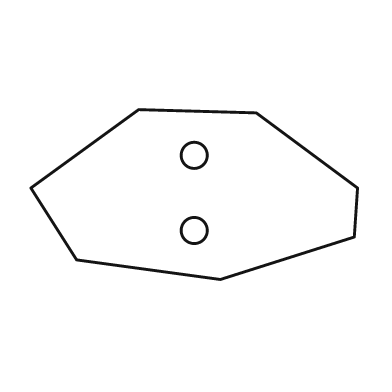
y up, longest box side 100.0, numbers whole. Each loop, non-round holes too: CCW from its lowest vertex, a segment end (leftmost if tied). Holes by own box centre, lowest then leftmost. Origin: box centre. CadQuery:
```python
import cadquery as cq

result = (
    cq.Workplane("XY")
    .moveTo(8.0, -26.0)
    .lineTo(49.0, -13.0)
    .lineTo(50.0, 2.0)
    .lineTo(19.0, 25.0)
    .lineTo(-17.0, 26.0)
    .lineTo(-50.0, 2.0)
    .lineTo(-36.0, -20.0)
    .close()
    .moveTo(0.0, -11.0)
    .circle(4.0)
    .moveTo(0.0, 12.0)
    .circle(4.0)
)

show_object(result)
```